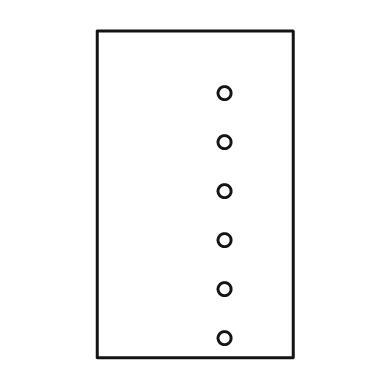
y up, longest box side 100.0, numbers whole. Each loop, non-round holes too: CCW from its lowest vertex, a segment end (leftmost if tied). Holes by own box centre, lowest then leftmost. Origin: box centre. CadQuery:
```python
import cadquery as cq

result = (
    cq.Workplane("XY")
    .moveTo(-30.0, -50.0)
    .lineTo(30.0, -50.0)
    .lineTo(30.0, 50.0)
    .lineTo(-30.0, 50.0)
    .close()
    .moveTo(9.0, -44.0)
    .circle(2.0)
    .moveTo(9.0, -29.0)
    .circle(2.0)
    .moveTo(9.0, -14.0)
    .circle(2.0)
    .moveTo(9.0, 1.0)
    .circle(2.0)
    .moveTo(9.0, 16.0)
    .circle(2.0)
    .moveTo(9.0, 31.0)
    .circle(2.0)
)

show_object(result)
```